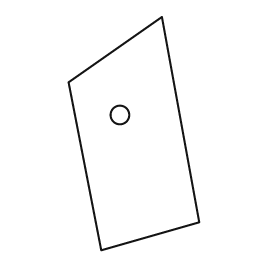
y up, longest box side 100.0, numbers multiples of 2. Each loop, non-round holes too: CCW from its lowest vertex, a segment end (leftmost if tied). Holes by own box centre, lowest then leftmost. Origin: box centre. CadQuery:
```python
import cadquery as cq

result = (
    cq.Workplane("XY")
    .moveTo(-14.0, -50.0)
    .lineTo(28.0, -38.0)
    .lineTo(12.0, 50.0)
    .lineTo(-28.0, 22.0)
    .close()
    .moveTo(-6.0, 8.0)
    .circle(4.0)
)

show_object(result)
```